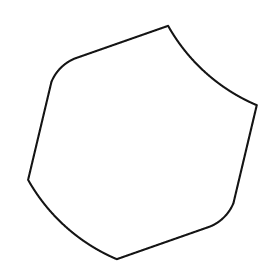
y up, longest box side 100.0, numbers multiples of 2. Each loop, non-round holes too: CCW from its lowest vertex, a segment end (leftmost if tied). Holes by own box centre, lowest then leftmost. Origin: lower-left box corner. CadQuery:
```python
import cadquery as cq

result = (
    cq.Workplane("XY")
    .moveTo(38.0, 0.0)
    .lineTo(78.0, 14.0)
    .threePointArc((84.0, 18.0), (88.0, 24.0))
    .lineTo(98.0, 66.0)
    .threePointArc((76.0, 80.0), (60.0, 100.0))
    .lineTo(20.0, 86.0)
    .threePointArc((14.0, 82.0), (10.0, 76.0))
    .lineTo(0.0, 34.0)
    .threePointArc((16.0, 14.0), (38.0, 0.0))
    .close()
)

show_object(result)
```